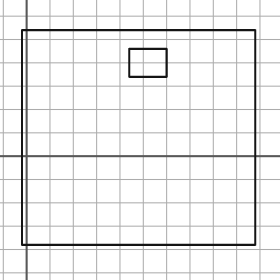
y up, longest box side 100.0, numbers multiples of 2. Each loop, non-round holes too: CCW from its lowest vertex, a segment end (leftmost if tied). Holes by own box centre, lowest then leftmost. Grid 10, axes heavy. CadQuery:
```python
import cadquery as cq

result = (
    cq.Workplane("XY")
    .moveTo(-2.0, -38.0)
    .lineTo(98.0, -38.0)
    .lineTo(98.0, 54.0)
    .lineTo(-2.0, 54.0)
    .close()
    .moveTo(44.0, 34.0)
    .lineTo(60.0, 34.0)
    .lineTo(60.0, 46.0)
    .lineTo(44.0, 46.0)
    .close()
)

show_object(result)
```